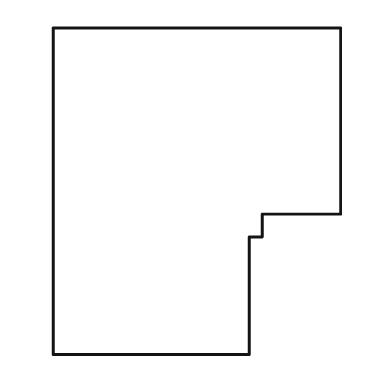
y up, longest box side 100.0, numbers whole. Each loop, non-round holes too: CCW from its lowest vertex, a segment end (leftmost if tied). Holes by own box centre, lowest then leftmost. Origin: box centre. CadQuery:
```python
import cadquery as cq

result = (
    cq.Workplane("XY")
    .moveTo(-44.0, -50.0)
    .lineTo(16.0, -50.0)
    .lineTo(16.0, -14.0)
    .lineTo(20.0, -14.0)
    .lineTo(20.0, -7.0)
    .lineTo(44.0, -7.0)
    .lineTo(44.0, 50.0)
    .lineTo(-44.0, 50.0)
    .close()
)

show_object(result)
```